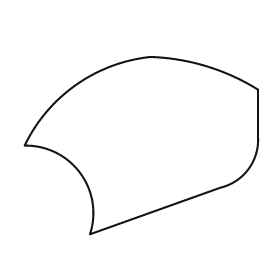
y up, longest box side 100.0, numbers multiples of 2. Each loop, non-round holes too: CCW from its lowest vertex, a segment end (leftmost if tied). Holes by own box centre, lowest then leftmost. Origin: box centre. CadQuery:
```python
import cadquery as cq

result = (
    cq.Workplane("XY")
    .moveTo(-22.0, -38.0)
    .lineTo(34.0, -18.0)
    .threePointArc((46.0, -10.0), (50.0, 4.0))
    .lineTo(50.0, 24.0)
    .threePointArc((28.0, 34.0), (4.0, 38.0))
    .threePointArc((-28.0, 26.0), (-50.0, 0.0))
    .threePointArc((-26.0, -12.0), (-22.0, -38.0))
    .close()
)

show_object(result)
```